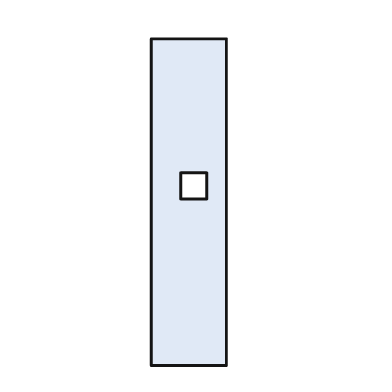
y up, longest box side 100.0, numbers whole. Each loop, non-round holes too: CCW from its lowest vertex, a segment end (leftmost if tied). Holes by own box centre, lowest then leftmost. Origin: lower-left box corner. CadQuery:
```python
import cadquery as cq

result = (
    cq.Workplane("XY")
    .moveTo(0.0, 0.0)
    .lineTo(23.0, 0.0)
    .lineTo(23.0, 100.0)
    .lineTo(0.0, 100.0)
    .close()
    .moveTo(9.0, 51.0)
    .lineTo(17.0, 51.0)
    .lineTo(17.0, 59.0)
    .lineTo(9.0, 59.0)
    .close()
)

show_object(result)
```